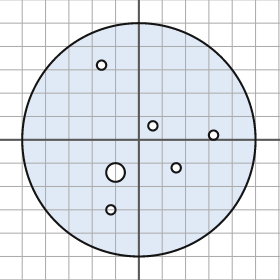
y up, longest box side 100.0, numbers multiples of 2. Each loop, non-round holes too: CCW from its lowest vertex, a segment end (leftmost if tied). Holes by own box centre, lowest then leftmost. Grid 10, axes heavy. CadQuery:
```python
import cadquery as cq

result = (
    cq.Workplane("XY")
    .moveTo(0.0, 0.0)
    .circle(50.0)
    .moveTo(-12.0, -30.0)
    .circle(2.0)
    .moveTo(-10.0, -14.0)
    .circle(4.0)
    .moveTo(16.0, -12.0)
    .circle(2.0)
    .moveTo(32.0, 2.0)
    .circle(2.0)
    .moveTo(6.0, 6.0)
    .circle(2.0)
    .moveTo(-16.0, 32.0)
    .circle(2.0)
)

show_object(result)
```